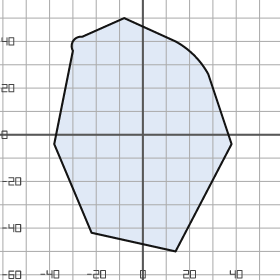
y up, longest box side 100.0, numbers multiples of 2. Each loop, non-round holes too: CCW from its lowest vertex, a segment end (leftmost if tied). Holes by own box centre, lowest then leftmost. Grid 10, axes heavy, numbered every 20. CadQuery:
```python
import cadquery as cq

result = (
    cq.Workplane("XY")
    .moveTo(14.0, -50.0)
    .lineTo(38.0, -4.0)
    .lineTo(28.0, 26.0)
    .threePointArc((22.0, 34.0), (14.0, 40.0))
    .lineTo(-8.0, 50.0)
    .lineTo(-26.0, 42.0)
    .threePointArc((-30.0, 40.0), (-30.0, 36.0))
    .lineTo(-38.0, -4.0)
    .lineTo(-22.0, -42.0)
    .close()
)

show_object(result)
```